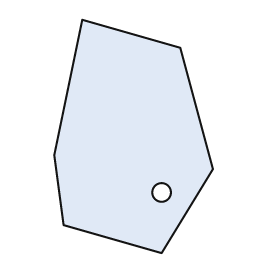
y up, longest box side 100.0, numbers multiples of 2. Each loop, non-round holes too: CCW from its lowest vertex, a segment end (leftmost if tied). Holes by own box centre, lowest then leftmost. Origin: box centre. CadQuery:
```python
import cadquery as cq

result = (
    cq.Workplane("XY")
    .moveTo(12.0, -50.0)
    .lineTo(34.0, -14.0)
    .lineTo(20.0, 38.0)
    .lineTo(-22.0, 50.0)
    .lineTo(-34.0, -8.0)
    .lineTo(-30.0, -38.0)
    .close()
    .moveTo(12.0, -24.0)
    .circle(4.0)
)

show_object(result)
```